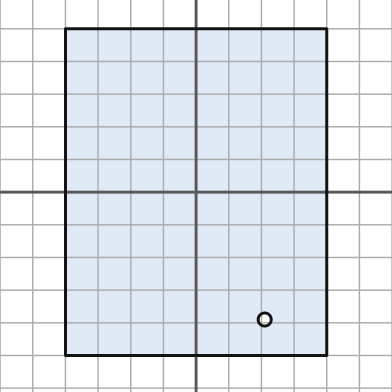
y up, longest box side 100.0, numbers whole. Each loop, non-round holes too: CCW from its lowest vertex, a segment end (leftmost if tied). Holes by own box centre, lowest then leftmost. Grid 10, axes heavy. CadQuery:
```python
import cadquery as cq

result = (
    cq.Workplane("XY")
    .moveTo(-40.0, -50.0)
    .lineTo(40.0, -50.0)
    .lineTo(40.0, 50.0)
    .lineTo(-40.0, 50.0)
    .close()
    .moveTo(21.0, -39.0)
    .circle(2.0)
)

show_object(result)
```